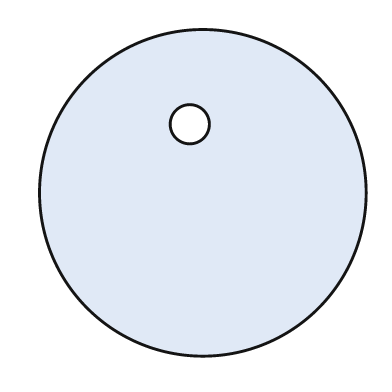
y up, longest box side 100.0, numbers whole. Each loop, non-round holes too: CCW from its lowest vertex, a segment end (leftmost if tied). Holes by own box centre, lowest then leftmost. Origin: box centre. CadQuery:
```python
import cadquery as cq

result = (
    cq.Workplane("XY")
    .moveTo(0.0, 0.0)
    .circle(50.0)
    .moveTo(-4.0, 21.0)
    .circle(6.0)
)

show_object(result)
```